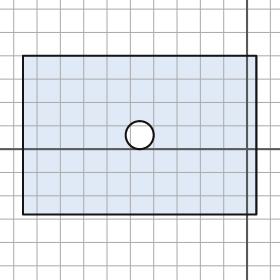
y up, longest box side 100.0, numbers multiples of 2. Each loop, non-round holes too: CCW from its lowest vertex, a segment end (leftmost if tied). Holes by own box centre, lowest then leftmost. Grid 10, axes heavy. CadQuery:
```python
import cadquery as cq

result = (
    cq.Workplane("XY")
    .moveTo(-96.0, -28.0)
    .lineTo(4.0, -28.0)
    .lineTo(4.0, 40.0)
    .lineTo(-96.0, 40.0)
    .close()
    .moveTo(-46.0, 6.0)
    .circle(6.0)
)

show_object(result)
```